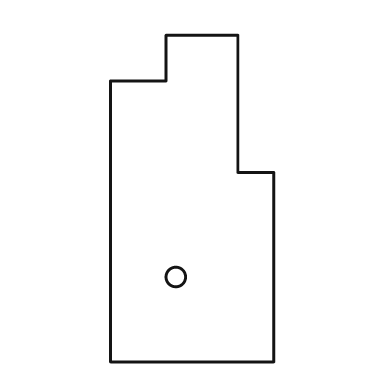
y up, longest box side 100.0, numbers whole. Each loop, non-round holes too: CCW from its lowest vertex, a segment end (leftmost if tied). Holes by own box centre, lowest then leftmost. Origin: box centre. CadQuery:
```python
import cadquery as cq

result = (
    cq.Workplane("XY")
    .moveTo(-25.0, -50.0)
    .lineTo(25.0, -50.0)
    .lineTo(25.0, 8.0)
    .lineTo(14.0, 8.0)
    .lineTo(14.0, 50.0)
    .lineTo(-8.0, 50.0)
    .lineTo(-8.0, 36.0)
    .lineTo(-25.0, 36.0)
    .close()
    .moveTo(-5.0, -24.0)
    .circle(3.0)
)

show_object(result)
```